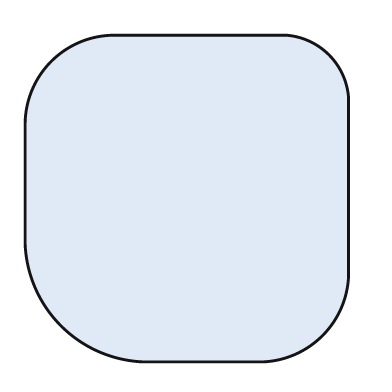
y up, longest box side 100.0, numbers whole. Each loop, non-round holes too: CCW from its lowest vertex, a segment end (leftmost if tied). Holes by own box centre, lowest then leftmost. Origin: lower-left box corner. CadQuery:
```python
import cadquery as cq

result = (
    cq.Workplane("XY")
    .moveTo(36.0, 0.0)
    .lineTo(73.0, 0.0)
    .threePointArc((91.0, 8.0), (99.0, 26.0))
    .lineTo(99.0, 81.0)
    .threePointArc((93.0, 94.0), (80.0, 100.0))
    .lineTo(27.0, 100.0)
    .threePointArc((8.0, 92.0), (0.0, 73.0))
    .lineTo(0.0, 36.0)
    .threePointArc((11.0, 11.0), (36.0, 0.0))
    .close()
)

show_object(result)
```